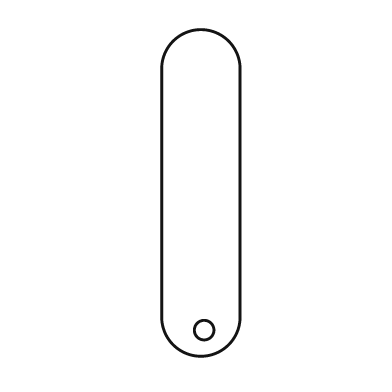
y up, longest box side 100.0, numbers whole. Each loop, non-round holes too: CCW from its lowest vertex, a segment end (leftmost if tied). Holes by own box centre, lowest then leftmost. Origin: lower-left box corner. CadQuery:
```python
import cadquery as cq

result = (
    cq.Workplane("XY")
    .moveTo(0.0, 12.0)
    .threePointArc((12.0, 0.0), (24.0, 12.0))
    .lineTo(24.0, 88.0)
    .threePointArc((12.0, 100.0), (0.0, 88.0))
    .close()
    .moveTo(13.0, 8.0)
    .circle(3.0)
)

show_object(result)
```